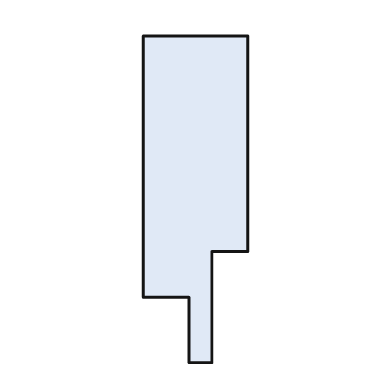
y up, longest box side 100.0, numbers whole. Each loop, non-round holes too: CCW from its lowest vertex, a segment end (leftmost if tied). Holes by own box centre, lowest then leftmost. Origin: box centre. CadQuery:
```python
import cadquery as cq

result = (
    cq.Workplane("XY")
    .moveTo(-2.0, -50.0)
    .lineTo(5.0, -50.0)
    .lineTo(5.0, -16.0)
    .lineTo(16.0, -16.0)
    .lineTo(16.0, 50.0)
    .lineTo(-16.0, 50.0)
    .lineTo(-16.0, -30.0)
    .lineTo(-2.0, -30.0)
    .close()
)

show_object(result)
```